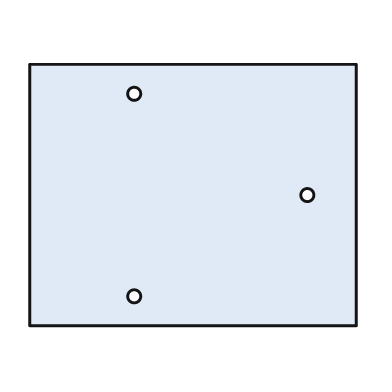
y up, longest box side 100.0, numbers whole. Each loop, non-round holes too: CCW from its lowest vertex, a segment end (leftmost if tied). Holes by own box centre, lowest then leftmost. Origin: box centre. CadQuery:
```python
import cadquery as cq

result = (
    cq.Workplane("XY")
    .moveTo(-50.0, -40.0)
    .lineTo(50.0, -40.0)
    .lineTo(50.0, 40.0)
    .lineTo(-50.0, 40.0)
    .close()
    .moveTo(-18.0, -31.0)
    .circle(2.0)
    .moveTo(35.0, 0.0)
    .circle(2.0)
    .moveTo(-18.0, 31.0)
    .circle(2.0)
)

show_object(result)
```